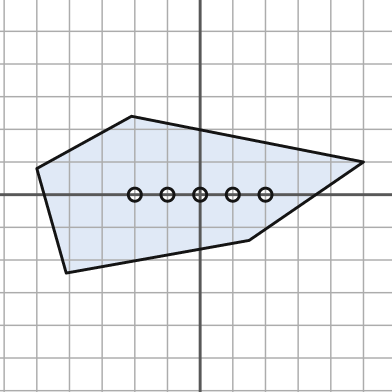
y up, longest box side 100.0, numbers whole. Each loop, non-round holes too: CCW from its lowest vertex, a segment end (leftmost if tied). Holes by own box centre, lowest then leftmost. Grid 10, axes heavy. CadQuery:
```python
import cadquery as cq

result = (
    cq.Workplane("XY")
    .moveTo(-41.0, -24.0)
    .lineTo(15.0, -14.0)
    .lineTo(50.0, 10.0)
    .lineTo(-21.0, 24.0)
    .lineTo(-50.0, 8.0)
    .close()
    .moveTo(-20.0, 0.0)
    .circle(2.0)
    .moveTo(-10.0, 0.0)
    .circle(2.0)
    .moveTo(0.0, 0.0)
    .circle(2.0)
    .moveTo(10.0, 0.0)
    .circle(2.0)
    .moveTo(20.0, 0.0)
    .circle(2.0)
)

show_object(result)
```